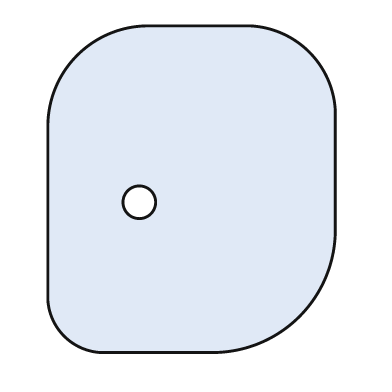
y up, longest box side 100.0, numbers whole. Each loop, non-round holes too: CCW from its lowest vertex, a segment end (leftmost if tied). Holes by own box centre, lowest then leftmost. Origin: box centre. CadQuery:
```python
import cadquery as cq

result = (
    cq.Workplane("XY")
    .moveTo(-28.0, -50.0)
    .lineTo(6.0, -50.0)
    .threePointArc((33.0, -39.0), (44.0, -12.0))
    .lineTo(44.0, 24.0)
    .threePointArc((36.0, 42.0), (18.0, 50.0))
    .lineTo(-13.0, 50.0)
    .threePointArc((-35.0, 41.0), (-44.0, 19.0))
    .lineTo(-44.0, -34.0)
    .threePointArc((-39.0, -45.0), (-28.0, -50.0))
    .close()
    .moveTo(-16.0, -4.0)
    .circle(5.0)
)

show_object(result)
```